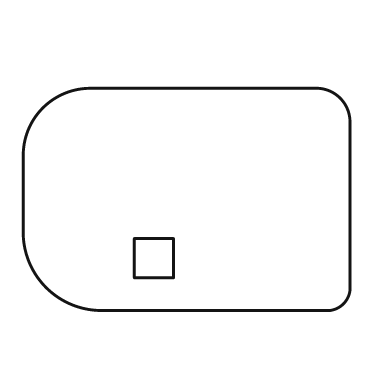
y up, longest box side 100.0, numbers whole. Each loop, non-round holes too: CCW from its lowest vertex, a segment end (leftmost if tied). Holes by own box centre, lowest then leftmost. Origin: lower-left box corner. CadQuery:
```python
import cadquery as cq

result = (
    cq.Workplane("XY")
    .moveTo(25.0, 0.0)
    .lineTo(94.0, 0.0)
    .threePointArc((98.0, 2.0), (100.0, 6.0))
    .lineTo(100.0, 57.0)
    .threePointArc((97.0, 65.0), (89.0, 68.0))
    .lineTo(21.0, 68.0)
    .threePointArc((6.0, 62.0), (0.0, 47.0))
    .lineTo(0.0, 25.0)
    .threePointArc((7.0, 7.0), (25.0, 0.0))
    .close()
    .moveTo(34.0, 10.0)
    .lineTo(46.0, 10.0)
    .lineTo(46.0, 22.0)
    .lineTo(34.0, 22.0)
    .close()
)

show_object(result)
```